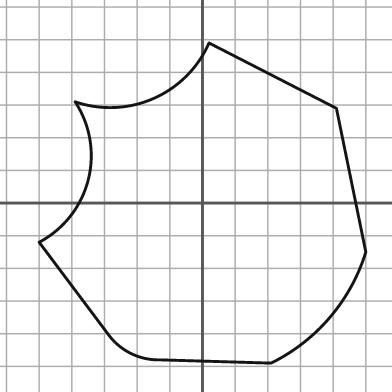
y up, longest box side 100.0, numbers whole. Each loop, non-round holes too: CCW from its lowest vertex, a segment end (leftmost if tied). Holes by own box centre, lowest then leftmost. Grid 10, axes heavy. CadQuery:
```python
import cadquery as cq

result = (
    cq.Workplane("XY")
    .moveTo(21.0, -49.0)
    .threePointArc((39.0, -35.0), (50.0, -15.0))
    .lineTo(41.0, 29.0)
    .lineTo(2.0, 49.0)
    .threePointArc((-15.0, 32.0), (-39.0, 31.0))
    .threePointArc((-35.0, 7.0), (-50.0, -12.0))
    .lineTo(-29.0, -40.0)
    .threePointArc((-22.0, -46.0), (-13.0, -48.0))
    .close()
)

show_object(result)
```